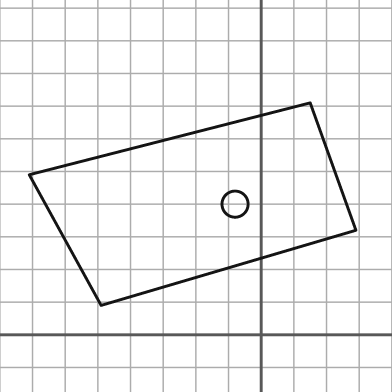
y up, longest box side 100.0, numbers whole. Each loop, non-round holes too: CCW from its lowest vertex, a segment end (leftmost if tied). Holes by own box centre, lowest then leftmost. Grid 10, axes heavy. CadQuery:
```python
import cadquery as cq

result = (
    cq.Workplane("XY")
    .moveTo(-49.0, 9.0)
    .lineTo(29.0, 32.0)
    .lineTo(15.0, 71.0)
    .lineTo(-71.0, 49.0)
    .close()
    .moveTo(-8.0, 40.0)
    .circle(4.0)
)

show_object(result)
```